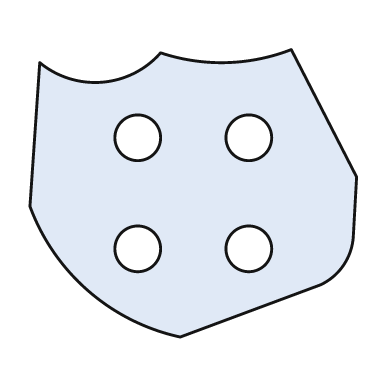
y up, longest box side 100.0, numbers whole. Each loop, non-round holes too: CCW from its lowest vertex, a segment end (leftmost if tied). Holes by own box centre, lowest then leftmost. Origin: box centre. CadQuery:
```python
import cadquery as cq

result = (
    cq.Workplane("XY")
    .moveTo(-4.0, -44.0)
    .lineTo(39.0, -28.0)
    .threePointArc((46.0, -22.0), (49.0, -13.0))
    .lineTo(50.0, 5.0)
    .lineTo(30.0, 44.0)
    .threePointArc((10.0, 40.0), (-10.0, 43.0))
    .threePointArc((-28.0, 34.0), (-47.0, 40.0))
    .lineTo(-50.0, -4.0)
    .threePointArc((-32.0, -30.0), (-4.0, -44.0))
    .close()
    .moveTo(-17.0, -17.0)
    .circle(7.0)
    .moveTo(17.0, -17.0)
    .circle(7.0)
    .moveTo(-17.0, 17.0)
    .circle(7.0)
    .moveTo(17.0, 17.0)
    .circle(7.0)
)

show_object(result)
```